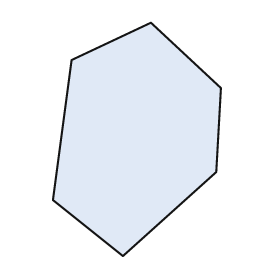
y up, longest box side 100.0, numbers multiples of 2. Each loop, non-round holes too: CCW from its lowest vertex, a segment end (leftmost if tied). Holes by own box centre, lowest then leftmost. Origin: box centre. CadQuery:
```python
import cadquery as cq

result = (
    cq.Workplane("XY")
    .moveTo(-6.0, -50.0)
    .lineTo(34.0, -14.0)
    .lineTo(36.0, 22.0)
    .lineTo(6.0, 50.0)
    .lineTo(-28.0, 34.0)
    .lineTo(-36.0, -26.0)
    .close()
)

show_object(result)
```